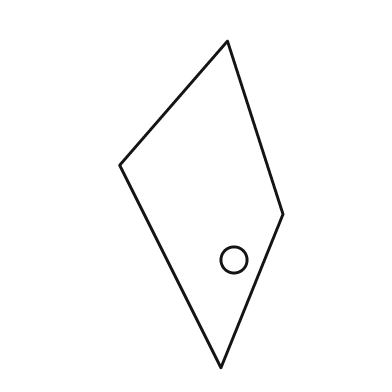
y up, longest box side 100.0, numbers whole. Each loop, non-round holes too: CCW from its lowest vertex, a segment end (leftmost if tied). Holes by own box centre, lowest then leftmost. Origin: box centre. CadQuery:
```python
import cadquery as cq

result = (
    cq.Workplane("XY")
    .moveTo(6.0, -50.0)
    .lineTo(25.0, -3.0)
    .lineTo(8.0, 50.0)
    .lineTo(-25.0, 12.0)
    .close()
    .moveTo(10.0, -17.0)
    .circle(4.0)
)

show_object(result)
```